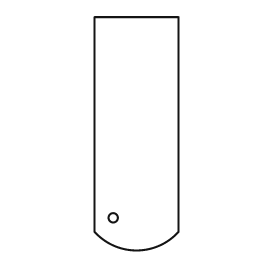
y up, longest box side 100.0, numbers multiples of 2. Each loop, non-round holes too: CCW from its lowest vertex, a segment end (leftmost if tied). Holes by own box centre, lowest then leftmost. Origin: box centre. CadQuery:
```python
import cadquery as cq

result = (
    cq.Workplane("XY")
    .moveTo(-18.0, -42.0)
    .threePointArc((0.0, -50.0), (18.0, -42.0))
    .lineTo(18.0, 50.0)
    .lineTo(-18.0, 50.0)
    .close()
    .moveTo(-10.0, -36.0)
    .circle(2.0)
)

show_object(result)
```